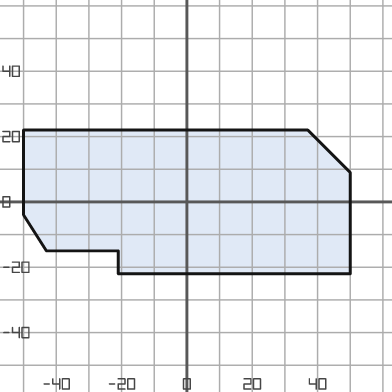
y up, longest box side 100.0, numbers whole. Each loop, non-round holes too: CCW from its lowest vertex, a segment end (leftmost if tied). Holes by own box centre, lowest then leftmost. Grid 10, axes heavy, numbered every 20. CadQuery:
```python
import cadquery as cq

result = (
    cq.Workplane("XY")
    .moveTo(-21.0, -22.0)
    .lineTo(50.0, -22.0)
    .lineTo(50.0, 9.0)
    .lineTo(37.0, 22.0)
    .lineTo(-50.0, 22.0)
    .lineTo(-50.0, -4.0)
    .lineTo(-43.0, -15.0)
    .lineTo(-21.0, -15.0)
    .close()
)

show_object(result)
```